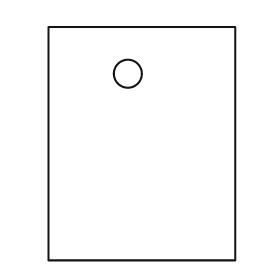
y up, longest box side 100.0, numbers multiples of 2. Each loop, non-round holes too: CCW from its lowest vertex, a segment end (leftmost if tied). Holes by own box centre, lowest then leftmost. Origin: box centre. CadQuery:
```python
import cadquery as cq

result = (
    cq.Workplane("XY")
    .moveTo(-40.0, -50.0)
    .lineTo(40.0, -50.0)
    .lineTo(40.0, 50.0)
    .lineTo(-40.0, 50.0)
    .close()
    .moveTo(-6.0, 30.0)
    .circle(6.0)
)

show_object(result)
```